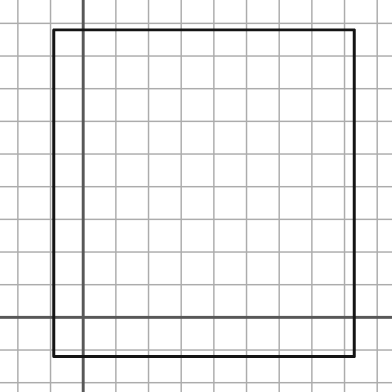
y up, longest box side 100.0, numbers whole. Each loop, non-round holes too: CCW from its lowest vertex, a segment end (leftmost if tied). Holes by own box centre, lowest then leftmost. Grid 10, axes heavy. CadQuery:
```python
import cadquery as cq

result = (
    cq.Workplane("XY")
    .moveTo(-9.0, -12.0)
    .lineTo(83.0, -12.0)
    .lineTo(83.0, 88.0)
    .lineTo(-9.0, 88.0)
    .close()
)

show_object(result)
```